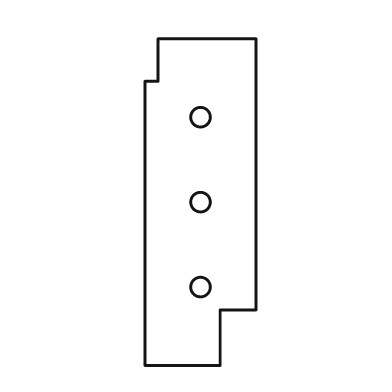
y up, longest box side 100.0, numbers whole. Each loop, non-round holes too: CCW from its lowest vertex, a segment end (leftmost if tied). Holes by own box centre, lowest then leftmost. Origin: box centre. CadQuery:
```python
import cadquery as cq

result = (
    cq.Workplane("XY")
    .moveTo(-17.0, -50.0)
    .lineTo(6.0, -50.0)
    .lineTo(6.0, -33.0)
    .lineTo(17.0, -33.0)
    .lineTo(17.0, 50.0)
    .lineTo(-13.0, 50.0)
    .lineTo(-13.0, 37.0)
    .lineTo(-17.0, 37.0)
    .close()
    .moveTo(0.0, -26.0)
    .circle(3.0)
    .moveTo(0.0, 0.0)
    .circle(3.0)
    .moveTo(0.0, 26.0)
    .circle(3.0)
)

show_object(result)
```